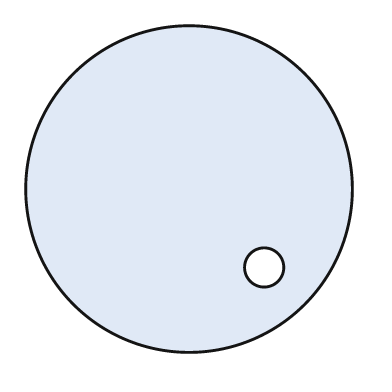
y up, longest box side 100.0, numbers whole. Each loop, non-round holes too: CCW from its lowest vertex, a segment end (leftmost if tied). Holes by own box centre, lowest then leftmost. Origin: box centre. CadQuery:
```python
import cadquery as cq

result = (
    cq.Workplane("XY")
    .moveTo(0.0, 0.0)
    .circle(50.0)
    .moveTo(23.0, -24.0)
    .circle(6.0)
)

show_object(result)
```